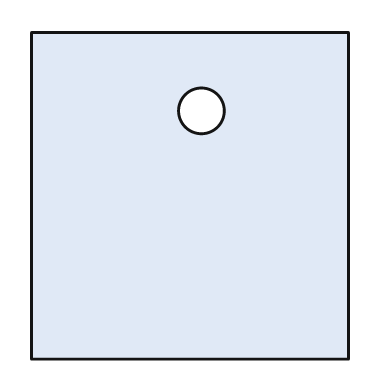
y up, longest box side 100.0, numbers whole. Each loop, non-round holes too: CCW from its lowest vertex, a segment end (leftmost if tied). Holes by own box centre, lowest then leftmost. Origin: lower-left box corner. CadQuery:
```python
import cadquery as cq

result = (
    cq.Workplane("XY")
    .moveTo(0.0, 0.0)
    .lineTo(97.0, 0.0)
    .lineTo(97.0, 100.0)
    .lineTo(0.0, 100.0)
    .close()
    .moveTo(52.0, 76.0)
    .circle(7.0)
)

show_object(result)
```